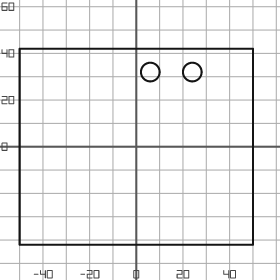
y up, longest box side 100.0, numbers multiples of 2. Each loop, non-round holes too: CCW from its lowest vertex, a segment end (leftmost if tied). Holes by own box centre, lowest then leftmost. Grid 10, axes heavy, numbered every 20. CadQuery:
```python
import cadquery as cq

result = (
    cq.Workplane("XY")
    .moveTo(-50.0, -42.0)
    .lineTo(50.0, -42.0)
    .lineTo(50.0, 42.0)
    .lineTo(-50.0, 42.0)
    .close()
    .moveTo(6.0, 32.0)
    .circle(4.0)
    .moveTo(24.0, 32.0)
    .circle(4.0)
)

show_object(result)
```